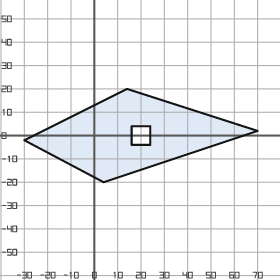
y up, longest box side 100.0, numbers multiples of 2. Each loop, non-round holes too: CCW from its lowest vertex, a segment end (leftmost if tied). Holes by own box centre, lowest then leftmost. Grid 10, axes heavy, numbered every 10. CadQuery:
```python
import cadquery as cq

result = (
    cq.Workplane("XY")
    .moveTo(4.0, -20.0)
    .lineTo(70.0, 2.0)
    .lineTo(14.0, 20.0)
    .lineTo(-30.0, -2.0)
    .close()
    .moveTo(16.0, -4.0)
    .lineTo(24.0, -4.0)
    .lineTo(24.0, 4.0)
    .lineTo(16.0, 4.0)
    .close()
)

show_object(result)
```